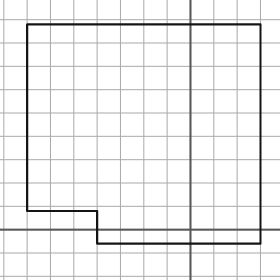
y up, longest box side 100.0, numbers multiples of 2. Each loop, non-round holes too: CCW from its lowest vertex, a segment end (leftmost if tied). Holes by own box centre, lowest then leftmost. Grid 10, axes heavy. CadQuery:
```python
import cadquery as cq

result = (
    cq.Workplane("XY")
    .moveTo(-40.0, -6.0)
    .lineTo(30.0, -6.0)
    .lineTo(30.0, 88.0)
    .lineTo(-70.0, 88.0)
    .lineTo(-70.0, 8.0)
    .lineTo(-40.0, 8.0)
    .close()
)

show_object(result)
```